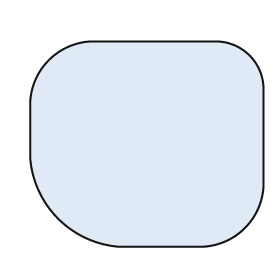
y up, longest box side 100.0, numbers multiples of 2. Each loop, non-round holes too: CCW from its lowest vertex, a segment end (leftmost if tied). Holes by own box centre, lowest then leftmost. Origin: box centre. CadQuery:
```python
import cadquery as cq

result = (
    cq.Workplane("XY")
    .moveTo(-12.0, -44.0)
    .lineTo(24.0, -44.0)
    .threePointArc((42.0, -36.0), (50.0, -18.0))
    .lineTo(50.0, 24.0)
    .threePointArc((44.0, 38.0), (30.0, 44.0))
    .lineTo(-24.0, 44.0)
    .threePointArc((-42.0, 36.0), (-50.0, 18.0))
    .lineTo(-50.0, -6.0)
    .threePointArc((-38.0, -32.0), (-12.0, -44.0))
    .close()
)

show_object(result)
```